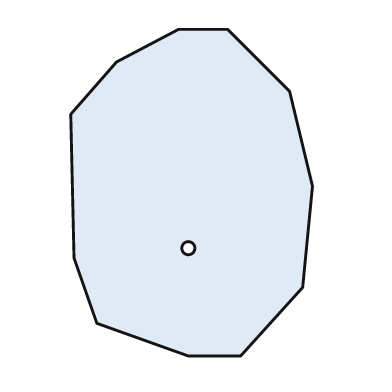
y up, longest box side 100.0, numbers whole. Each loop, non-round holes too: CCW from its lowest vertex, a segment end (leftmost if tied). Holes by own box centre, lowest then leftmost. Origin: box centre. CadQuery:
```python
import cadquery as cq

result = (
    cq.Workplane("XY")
    .moveTo(-1.0, -50.0)
    .lineTo(15.0, -50.0)
    .lineTo(34.0, -29.0)
    .lineTo(37.0, 2.0)
    .lineTo(30.0, 31.0)
    .lineTo(11.0, 50.0)
    .lineTo(-4.0, 50.0)
    .lineTo(-23.0, 40.0)
    .lineTo(-37.0, 24.0)
    .lineTo(-36.0, -20.0)
    .lineTo(-29.0, -40.0)
    .close()
    .moveTo(-1.0, -17.0)
    .circle(2.0)
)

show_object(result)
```